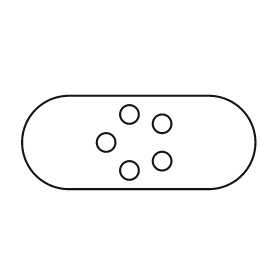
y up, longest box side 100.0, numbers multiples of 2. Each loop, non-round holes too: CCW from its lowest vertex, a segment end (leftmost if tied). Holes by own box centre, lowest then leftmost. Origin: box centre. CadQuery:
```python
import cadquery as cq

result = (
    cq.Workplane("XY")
    .moveTo(-30.0, -20.0)
    .lineTo(30.0, -20.0)
    .threePointArc((50.0, 0.0), (30.0, 20.0))
    .lineTo(-30.0, 20.0)
    .threePointArc((-50.0, 0.0), (-30.0, -20.0))
    .close()
    .moveTo(-4.0, -12.0)
    .circle(4.0)
    .moveTo(10.0, -8.0)
    .circle(4.0)
    .moveTo(-14.0, 0.0)
    .circle(4.0)
    .moveTo(10.0, 8.0)
    .circle(4.0)
    .moveTo(-4.0, 12.0)
    .circle(4.0)
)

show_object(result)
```